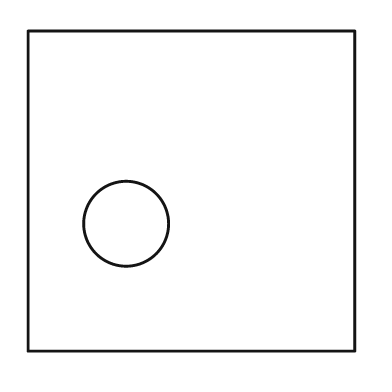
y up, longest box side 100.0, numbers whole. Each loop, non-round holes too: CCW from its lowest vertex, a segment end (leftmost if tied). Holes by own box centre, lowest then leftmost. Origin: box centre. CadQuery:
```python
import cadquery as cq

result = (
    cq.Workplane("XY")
    .moveTo(-50.0, -49.0)
    .lineTo(50.0, -49.0)
    .lineTo(50.0, 49.0)
    .lineTo(-50.0, 49.0)
    .close()
    .moveTo(-20.0, -10.0)
    .circle(13.0)
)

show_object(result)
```